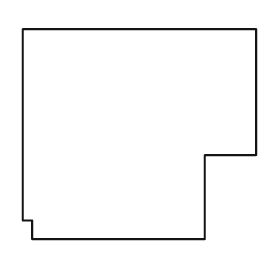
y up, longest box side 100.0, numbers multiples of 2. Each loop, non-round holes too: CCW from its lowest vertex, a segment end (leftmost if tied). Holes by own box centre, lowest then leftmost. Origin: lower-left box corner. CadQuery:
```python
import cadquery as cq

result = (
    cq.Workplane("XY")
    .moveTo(4.0, 0.0)
    .lineTo(78.0, 0.0)
    .lineTo(78.0, 36.0)
    .lineTo(100.0, 36.0)
    .lineTo(100.0, 90.0)
    .lineTo(0.0, 90.0)
    .lineTo(0.0, 8.0)
    .lineTo(4.0, 8.0)
    .close()
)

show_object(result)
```